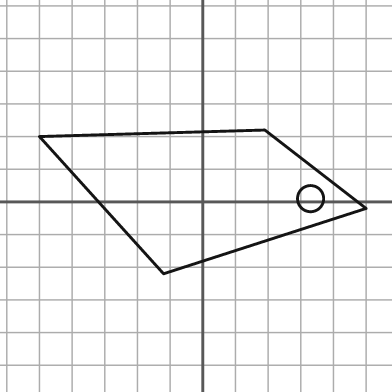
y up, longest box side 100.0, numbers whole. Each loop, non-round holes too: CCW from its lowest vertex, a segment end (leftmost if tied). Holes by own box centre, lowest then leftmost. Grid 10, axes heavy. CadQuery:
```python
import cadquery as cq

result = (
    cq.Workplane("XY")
    .moveTo(-12.0, -22.0)
    .lineTo(50.0, -2.0)
    .lineTo(19.0, 22.0)
    .lineTo(-50.0, 20.0)
    .close()
    .moveTo(33.0, 1.0)
    .circle(4.0)
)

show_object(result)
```